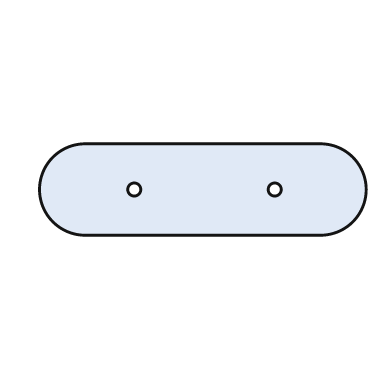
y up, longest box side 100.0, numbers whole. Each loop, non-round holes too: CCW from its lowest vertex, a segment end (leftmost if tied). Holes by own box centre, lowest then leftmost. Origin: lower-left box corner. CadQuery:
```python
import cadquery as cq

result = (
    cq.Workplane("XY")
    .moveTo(14.0, 0.0)
    .lineTo(86.0, 0.0)
    .threePointArc((100.0, 14.0), (86.0, 28.0))
    .lineTo(14.0, 28.0)
    .threePointArc((0.0, 14.0), (14.0, 0.0))
    .close()
    .moveTo(29.0, 14.0)
    .circle(2.0)
    .moveTo(72.0, 14.0)
    .circle(2.0)
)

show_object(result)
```